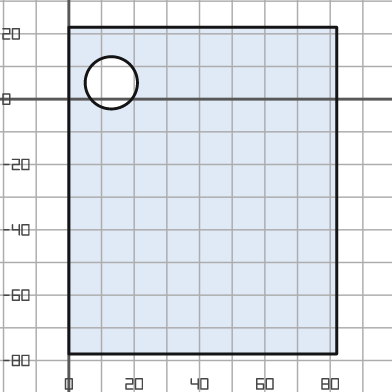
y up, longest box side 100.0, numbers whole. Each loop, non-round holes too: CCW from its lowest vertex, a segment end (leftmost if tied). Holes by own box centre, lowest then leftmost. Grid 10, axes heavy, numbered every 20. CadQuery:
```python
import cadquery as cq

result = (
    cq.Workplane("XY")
    .moveTo(0.0, -78.0)
    .lineTo(82.0, -78.0)
    .lineTo(82.0, 22.0)
    .lineTo(0.0, 22.0)
    .close()
    .moveTo(13.0, 5.0)
    .circle(8.0)
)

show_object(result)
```